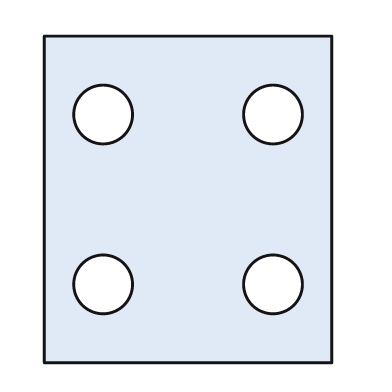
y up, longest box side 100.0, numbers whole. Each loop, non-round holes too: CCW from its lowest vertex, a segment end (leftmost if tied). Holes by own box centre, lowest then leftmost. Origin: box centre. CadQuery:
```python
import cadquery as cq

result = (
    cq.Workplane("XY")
    .moveTo(-44.0, -50.0)
    .lineTo(44.0, -50.0)
    .lineTo(44.0, 50.0)
    .lineTo(-44.0, 50.0)
    .close()
    .moveTo(-26.0, -26.0)
    .circle(9.0)
    .moveTo(26.0, -26.0)
    .circle(9.0)
    .moveTo(-26.0, 26.0)
    .circle(9.0)
    .moveTo(26.0, 26.0)
    .circle(9.0)
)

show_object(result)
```